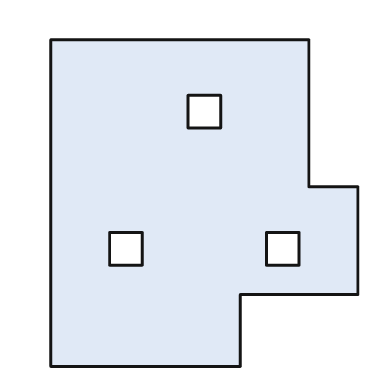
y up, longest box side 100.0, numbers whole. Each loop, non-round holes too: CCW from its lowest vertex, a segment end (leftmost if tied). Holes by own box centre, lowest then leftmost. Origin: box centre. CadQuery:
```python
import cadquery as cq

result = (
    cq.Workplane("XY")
    .moveTo(-47.0, -50.0)
    .lineTo(11.0, -50.0)
    .lineTo(11.0, -28.0)
    .lineTo(47.0, -28.0)
    .lineTo(47.0, 5.0)
    .lineTo(32.0, 5.0)
    .lineTo(32.0, 50.0)
    .lineTo(-47.0, 50.0)
    .close()
    .moveTo(-29.0, -19.0)
    .lineTo(-19.0, -19.0)
    .lineTo(-19.0, -9.0)
    .lineTo(-29.0, -9.0)
    .close()
    .moveTo(19.0, -19.0)
    .lineTo(29.0, -19.0)
    .lineTo(29.0, -9.0)
    .lineTo(19.0, -9.0)
    .close()
    .moveTo(-5.0, 23.0)
    .lineTo(5.0, 23.0)
    .lineTo(5.0, 33.0)
    .lineTo(-5.0, 33.0)
    .close()
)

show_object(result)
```